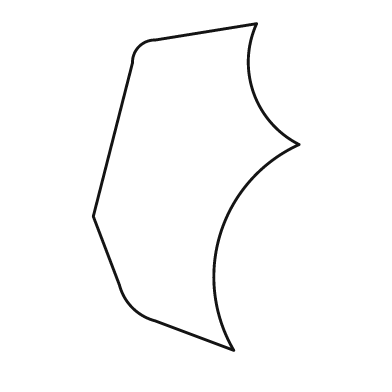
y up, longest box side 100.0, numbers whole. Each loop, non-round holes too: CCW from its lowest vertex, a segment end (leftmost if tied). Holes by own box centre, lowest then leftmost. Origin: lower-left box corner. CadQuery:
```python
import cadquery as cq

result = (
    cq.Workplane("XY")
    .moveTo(43.0, 0.0)
    .threePointArc((39.0, 36.0), (63.0, 63.0))
    .threePointArc((49.0, 79.0), (50.0, 100.0))
    .lineTo(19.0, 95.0)
    .threePointArc((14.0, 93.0), (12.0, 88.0))
    .lineTo(0.0, 41.0)
    .lineTo(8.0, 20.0)
    .threePointArc((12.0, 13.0), (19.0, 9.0))
    .close()
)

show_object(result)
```